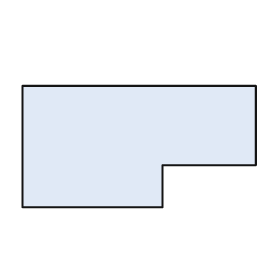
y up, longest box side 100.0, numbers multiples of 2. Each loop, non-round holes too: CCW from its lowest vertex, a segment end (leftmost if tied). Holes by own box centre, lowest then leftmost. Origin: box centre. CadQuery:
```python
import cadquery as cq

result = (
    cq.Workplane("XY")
    .moveTo(-50.0, -26.0)
    .lineTo(10.0, -26.0)
    .lineTo(10.0, -8.0)
    .lineTo(50.0, -8.0)
    .lineTo(50.0, 26.0)
    .lineTo(-50.0, 26.0)
    .close()
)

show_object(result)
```